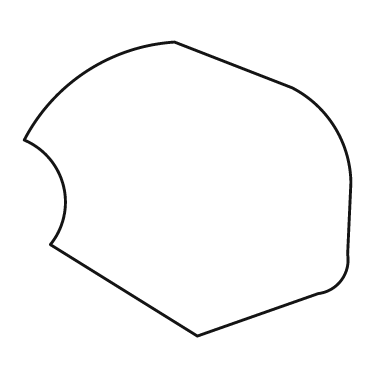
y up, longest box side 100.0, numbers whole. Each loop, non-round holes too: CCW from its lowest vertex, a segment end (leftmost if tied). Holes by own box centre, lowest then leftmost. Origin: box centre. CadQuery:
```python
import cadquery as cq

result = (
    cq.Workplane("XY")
    .moveTo(3.0, -45.0)
    .lineTo(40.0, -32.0)
    .threePointArc((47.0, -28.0), (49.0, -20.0))
    .lineTo(50.0, 2.0)
    .threePointArc((45.0, 19.0), (32.0, 31.0))
    .lineTo(-4.0, 45.0)
    .threePointArc((-31.0, 36.0), (-50.0, 15.0))
    .threePointArc((-38.0, 1.0), (-42.0, -17.0))
    .close()
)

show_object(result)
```